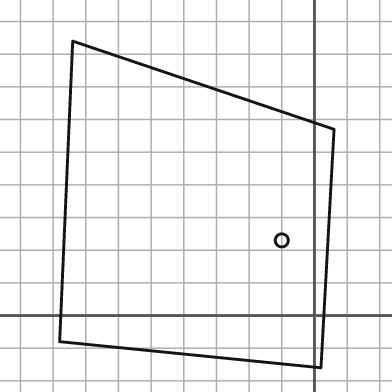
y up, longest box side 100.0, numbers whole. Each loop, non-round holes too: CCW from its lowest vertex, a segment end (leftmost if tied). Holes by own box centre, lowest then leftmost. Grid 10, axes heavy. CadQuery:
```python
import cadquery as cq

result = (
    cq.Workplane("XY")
    .moveTo(2.0, -16.0)
    .lineTo(6.0, 57.0)
    .lineTo(-74.0, 84.0)
    .lineTo(-78.0, -8.0)
    .close()
    .moveTo(-10.0, 23.0)
    .circle(2.0)
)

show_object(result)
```